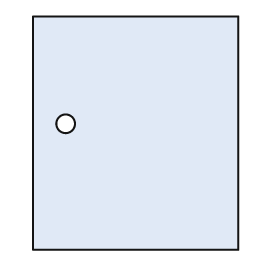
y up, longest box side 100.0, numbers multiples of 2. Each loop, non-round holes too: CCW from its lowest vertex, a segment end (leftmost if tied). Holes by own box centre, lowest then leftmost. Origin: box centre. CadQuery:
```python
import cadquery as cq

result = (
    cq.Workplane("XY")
    .moveTo(-44.0, -50.0)
    .lineTo(44.0, -50.0)
    .lineTo(44.0, 50.0)
    .lineTo(-44.0, 50.0)
    .close()
    .moveTo(-30.0, 4.0)
    .circle(4.0)
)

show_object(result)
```